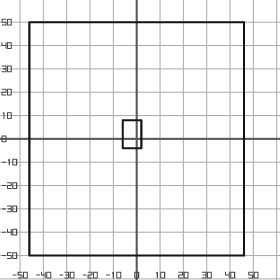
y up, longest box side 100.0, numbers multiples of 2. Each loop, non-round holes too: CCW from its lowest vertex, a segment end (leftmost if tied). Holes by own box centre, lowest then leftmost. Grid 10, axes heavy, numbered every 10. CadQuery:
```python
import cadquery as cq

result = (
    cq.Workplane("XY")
    .moveTo(-46.0, -50.0)
    .lineTo(46.0, -50.0)
    .lineTo(46.0, 50.0)
    .lineTo(-46.0, 50.0)
    .close()
    .moveTo(-6.0, -4.0)
    .lineTo(2.0, -4.0)
    .lineTo(2.0, 8.0)
    .lineTo(-6.0, 8.0)
    .close()
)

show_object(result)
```